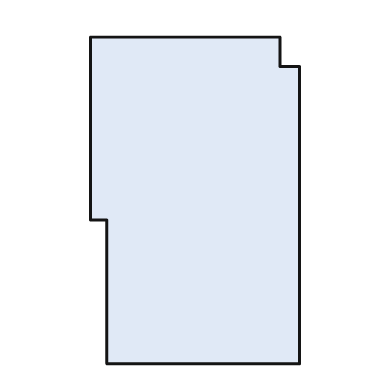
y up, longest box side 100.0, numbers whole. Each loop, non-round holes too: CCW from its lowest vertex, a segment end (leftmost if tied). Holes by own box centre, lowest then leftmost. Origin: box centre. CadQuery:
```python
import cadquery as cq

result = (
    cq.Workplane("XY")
    .moveTo(-27.0, -50.0)
    .lineTo(32.0, -50.0)
    .lineTo(32.0, 41.0)
    .lineTo(26.0, 41.0)
    .lineTo(26.0, 50.0)
    .lineTo(-32.0, 50.0)
    .lineTo(-32.0, -6.0)
    .lineTo(-27.0, -6.0)
    .close()
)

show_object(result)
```